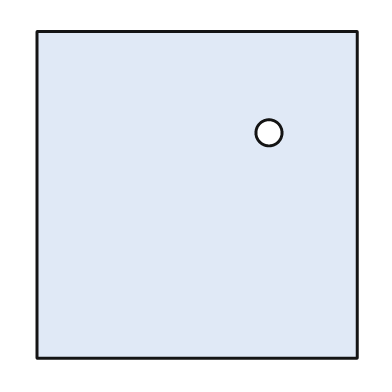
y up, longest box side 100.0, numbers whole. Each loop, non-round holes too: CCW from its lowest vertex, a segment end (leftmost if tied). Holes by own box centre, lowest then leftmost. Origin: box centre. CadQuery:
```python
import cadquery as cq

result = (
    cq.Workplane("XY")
    .moveTo(-49.0, -50.0)
    .lineTo(49.0, -50.0)
    .lineTo(49.0, 50.0)
    .lineTo(-49.0, 50.0)
    .close()
    .moveTo(22.0, 19.0)
    .circle(4.0)
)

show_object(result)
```